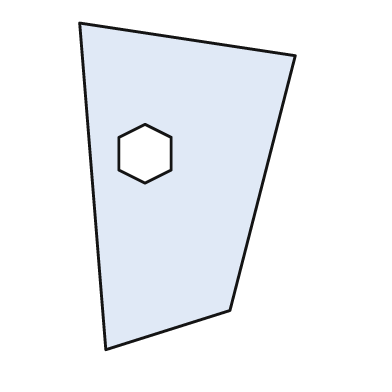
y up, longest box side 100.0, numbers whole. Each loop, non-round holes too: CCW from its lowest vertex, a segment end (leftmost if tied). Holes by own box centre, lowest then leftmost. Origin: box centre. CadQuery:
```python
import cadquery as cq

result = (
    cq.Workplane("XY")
    .moveTo(-25.0, -50.0)
    .lineTo(13.0, -38.0)
    .lineTo(33.0, 40.0)
    .lineTo(-33.0, 50.0)
    .close()
    .moveTo(-13.0, 1.0)
    .lineTo(-5.0, 5.0)
    .lineTo(-5.0, 15.0)
    .lineTo(-13.0, 19.0)
    .lineTo(-21.0, 15.0)
    .lineTo(-21.0, 5.0)
    .close()
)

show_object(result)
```